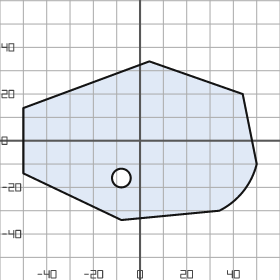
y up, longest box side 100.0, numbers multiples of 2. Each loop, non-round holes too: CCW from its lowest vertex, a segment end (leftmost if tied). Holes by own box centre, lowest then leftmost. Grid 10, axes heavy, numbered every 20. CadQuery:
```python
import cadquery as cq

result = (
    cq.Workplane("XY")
    .moveTo(-8.0, -34.0)
    .lineTo(34.0, -30.0)
    .threePointArc((44.0, -22.0), (50.0, -10.0))
    .lineTo(44.0, 20.0)
    .lineTo(4.0, 34.0)
    .lineTo(-50.0, 14.0)
    .lineTo(-50.0, -14.0)
    .close()
    .moveTo(-8.0, -16.0)
    .circle(4.0)
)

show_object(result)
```